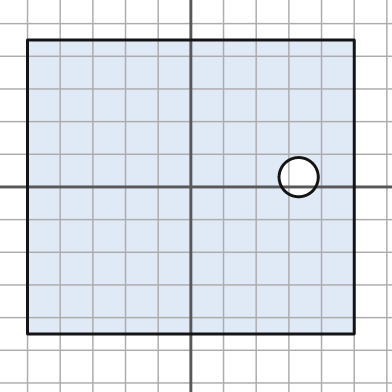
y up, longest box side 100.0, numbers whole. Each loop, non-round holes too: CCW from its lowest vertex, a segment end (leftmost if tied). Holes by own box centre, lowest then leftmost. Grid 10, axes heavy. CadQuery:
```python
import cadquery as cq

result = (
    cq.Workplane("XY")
    .moveTo(-50.0, -45.0)
    .lineTo(50.0, -45.0)
    .lineTo(50.0, 45.0)
    .lineTo(-50.0, 45.0)
    .close()
    .moveTo(33.0, 3.0)
    .circle(6.0)
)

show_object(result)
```